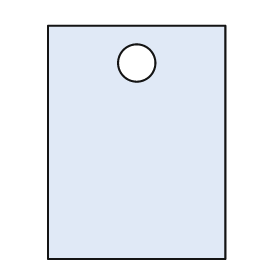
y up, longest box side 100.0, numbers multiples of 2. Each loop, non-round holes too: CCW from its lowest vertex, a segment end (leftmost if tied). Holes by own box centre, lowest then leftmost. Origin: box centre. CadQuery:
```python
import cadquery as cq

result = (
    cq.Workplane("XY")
    .moveTo(-38.0, -50.0)
    .lineTo(38.0, -50.0)
    .lineTo(38.0, 50.0)
    .lineTo(-38.0, 50.0)
    .close()
    .moveTo(0.0, 34.0)
    .circle(8.0)
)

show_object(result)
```